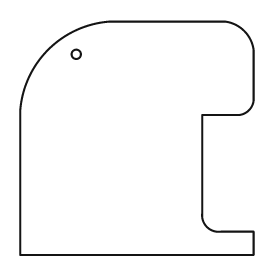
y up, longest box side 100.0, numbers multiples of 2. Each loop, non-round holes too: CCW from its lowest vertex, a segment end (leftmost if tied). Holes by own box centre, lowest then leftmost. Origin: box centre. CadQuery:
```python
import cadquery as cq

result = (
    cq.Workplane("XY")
    .moveTo(-50.0, -50.0)
    .lineTo(50.0, -50.0)
    .lineTo(50.0, -40.0)
    .lineTo(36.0, -40.0)
    .threePointArc((30.0, -38.0), (28.0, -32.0))
    .lineTo(28.0, 10.0)
    .lineTo(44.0, 10.0)
    .threePointArc((48.0, 12.0), (50.0, 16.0))
    .lineTo(50.0, 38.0)
    .threePointArc((46.0, 46.0), (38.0, 50.0))
    .lineTo(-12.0, 50.0)
    .threePointArc((-38.0, 38.0), (-50.0, 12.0))
    .close()
    .moveTo(-26.0, 36.0)
    .circle(2.0)
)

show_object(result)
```